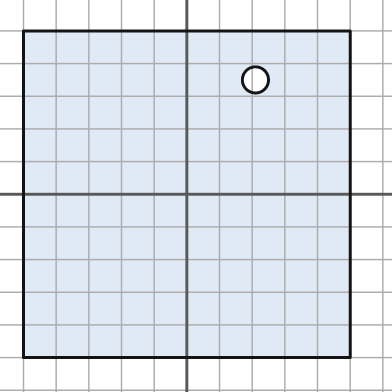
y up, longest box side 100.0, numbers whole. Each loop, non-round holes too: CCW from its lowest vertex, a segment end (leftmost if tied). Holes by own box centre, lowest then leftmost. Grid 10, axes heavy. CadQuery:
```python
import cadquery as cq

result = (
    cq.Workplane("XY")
    .moveTo(-50.0, -50.0)
    .lineTo(50.0, -50.0)
    .lineTo(50.0, 50.0)
    .lineTo(-50.0, 50.0)
    .close()
    .moveTo(21.0, 35.0)
    .circle(4.0)
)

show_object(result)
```